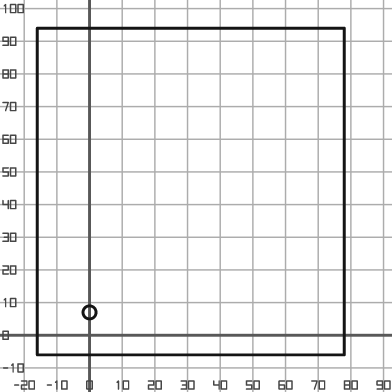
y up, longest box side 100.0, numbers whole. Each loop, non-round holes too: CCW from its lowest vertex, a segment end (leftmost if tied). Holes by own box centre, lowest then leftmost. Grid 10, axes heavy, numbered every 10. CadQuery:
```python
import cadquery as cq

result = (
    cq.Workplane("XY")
    .moveTo(-16.0, -6.0)
    .lineTo(78.0, -6.0)
    .lineTo(78.0, 94.0)
    .lineTo(-16.0, 94.0)
    .close()
    .moveTo(0.0, 7.0)
    .circle(2.0)
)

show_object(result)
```